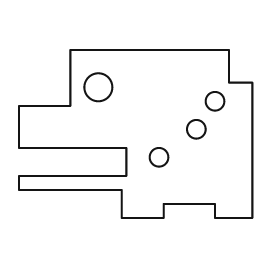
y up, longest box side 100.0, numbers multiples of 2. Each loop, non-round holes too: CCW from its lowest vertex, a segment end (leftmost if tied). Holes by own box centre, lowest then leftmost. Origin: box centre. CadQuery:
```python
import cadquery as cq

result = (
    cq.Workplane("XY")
    .moveTo(-6.0, -36.0)
    .lineTo(12.0, -36.0)
    .lineTo(12.0, -30.0)
    .lineTo(34.0, -30.0)
    .lineTo(34.0, -36.0)
    .lineTo(50.0, -36.0)
    .lineTo(50.0, 22.0)
    .lineTo(40.0, 22.0)
    .lineTo(40.0, 36.0)
    .lineTo(-28.0, 36.0)
    .lineTo(-28.0, 12.0)
    .lineTo(-50.0, 12.0)
    .lineTo(-50.0, -6.0)
    .lineTo(-4.0, -6.0)
    .lineTo(-4.0, -18.0)
    .lineTo(-50.0, -18.0)
    .lineTo(-50.0, -24.0)
    .lineTo(-6.0, -24.0)
    .close()
    .moveTo(10.0, -10.0)
    .circle(4.0)
    .moveTo(26.0, 2.0)
    .circle(4.0)
    .moveTo(34.0, 14.0)
    .circle(4.0)
    .moveTo(-16.0, 20.0)
    .circle(6.0)
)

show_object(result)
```